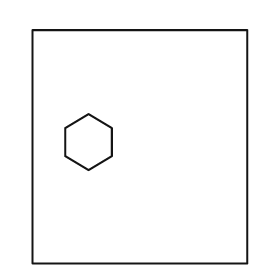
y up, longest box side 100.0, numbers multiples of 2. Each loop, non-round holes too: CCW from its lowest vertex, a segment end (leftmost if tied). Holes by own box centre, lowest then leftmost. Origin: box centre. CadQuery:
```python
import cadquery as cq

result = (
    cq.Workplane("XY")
    .moveTo(-46.0, -50.0)
    .lineTo(46.0, -50.0)
    .lineTo(46.0, 50.0)
    .lineTo(-46.0, 50.0)
    .close()
    .moveTo(-22.0, -10.0)
    .lineTo(-12.0, -4.0)
    .lineTo(-12.0, 8.0)
    .lineTo(-22.0, 14.0)
    .lineTo(-32.0, 8.0)
    .lineTo(-32.0, -4.0)
    .close()
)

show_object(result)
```